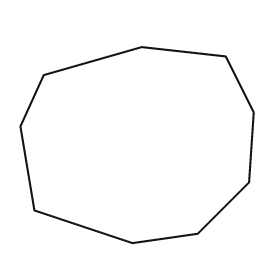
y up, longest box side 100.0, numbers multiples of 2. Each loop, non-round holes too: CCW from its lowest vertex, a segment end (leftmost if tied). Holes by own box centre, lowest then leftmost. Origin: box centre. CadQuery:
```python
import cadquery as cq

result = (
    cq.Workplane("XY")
    .moveTo(-2.0, -42.0)
    .lineTo(26.0, -38.0)
    .lineTo(48.0, -16.0)
    .lineTo(50.0, 14.0)
    .lineTo(38.0, 38.0)
    .lineTo(2.0, 42.0)
    .lineTo(-40.0, 30.0)
    .lineTo(-50.0, 8.0)
    .lineTo(-44.0, -28.0)
    .close()
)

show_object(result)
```